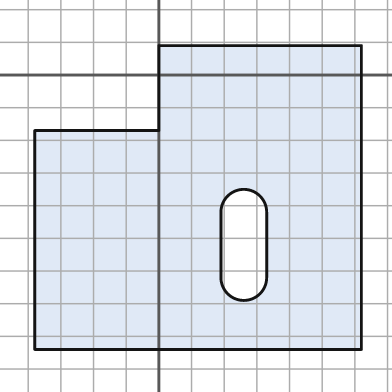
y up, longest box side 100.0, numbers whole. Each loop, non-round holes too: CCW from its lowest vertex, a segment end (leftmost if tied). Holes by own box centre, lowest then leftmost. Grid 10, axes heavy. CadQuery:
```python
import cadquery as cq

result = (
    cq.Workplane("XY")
    .moveTo(-38.0, -84.0)
    .lineTo(62.0, -84.0)
    .lineTo(62.0, 9.0)
    .lineTo(0.0, 9.0)
    .lineTo(0.0, -17.0)
    .lineTo(-38.0, -17.0)
    .close()
    .moveTo(19.0, -62.0)
    .threePointArc((26.0, -69.0), (33.0, -62.0))
    .lineTo(33.0, -42.0)
    .threePointArc((26.0, -35.0), (19.0, -42.0))
    .close()
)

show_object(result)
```